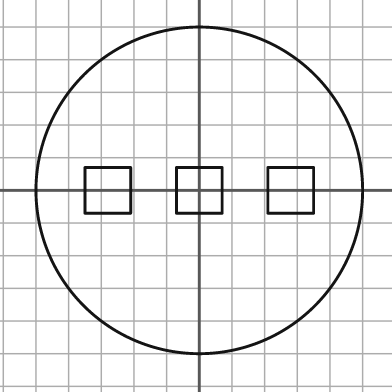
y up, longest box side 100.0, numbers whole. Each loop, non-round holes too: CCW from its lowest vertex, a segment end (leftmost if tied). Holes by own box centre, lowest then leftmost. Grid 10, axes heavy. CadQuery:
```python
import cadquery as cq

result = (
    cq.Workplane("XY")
    .moveTo(0.0, 0.0)
    .circle(50.0)
    .moveTo(-35.0, -7.0)
    .lineTo(-21.0, -7.0)
    .lineTo(-21.0, 7.0)
    .lineTo(-35.0, 7.0)
    .close()
    .moveTo(-7.0, -7.0)
    .lineTo(7.0, -7.0)
    .lineTo(7.0, 7.0)
    .lineTo(-7.0, 7.0)
    .close()
    .moveTo(21.0, -7.0)
    .lineTo(35.0, -7.0)
    .lineTo(35.0, 7.0)
    .lineTo(21.0, 7.0)
    .close()
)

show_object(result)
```